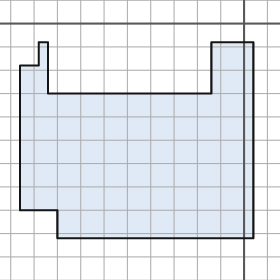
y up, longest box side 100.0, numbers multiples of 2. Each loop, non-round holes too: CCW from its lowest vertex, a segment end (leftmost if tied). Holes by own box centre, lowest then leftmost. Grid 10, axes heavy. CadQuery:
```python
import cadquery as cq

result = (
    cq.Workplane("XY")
    .moveTo(-80.0, -92.0)
    .lineTo(4.0, -92.0)
    .lineTo(4.0, -8.0)
    .lineTo(-14.0, -8.0)
    .lineTo(-14.0, -30.0)
    .lineTo(-84.0, -30.0)
    .lineTo(-84.0, -8.0)
    .lineTo(-88.0, -8.0)
    .lineTo(-88.0, -18.0)
    .lineTo(-96.0, -18.0)
    .lineTo(-96.0, -80.0)
    .lineTo(-80.0, -80.0)
    .close()
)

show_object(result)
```